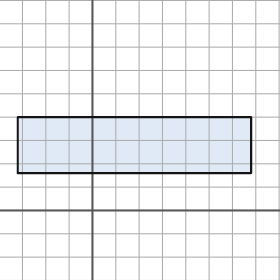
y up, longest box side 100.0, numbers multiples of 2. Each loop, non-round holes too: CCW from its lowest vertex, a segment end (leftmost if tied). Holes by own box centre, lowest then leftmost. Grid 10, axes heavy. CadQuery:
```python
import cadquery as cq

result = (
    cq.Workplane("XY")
    .moveTo(-32.0, 16.0)
    .lineTo(68.0, 16.0)
    .lineTo(68.0, 40.0)
    .lineTo(-32.0, 40.0)
    .close()
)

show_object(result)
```